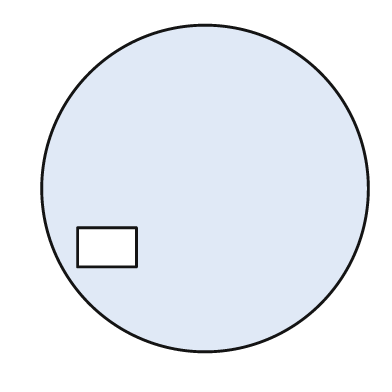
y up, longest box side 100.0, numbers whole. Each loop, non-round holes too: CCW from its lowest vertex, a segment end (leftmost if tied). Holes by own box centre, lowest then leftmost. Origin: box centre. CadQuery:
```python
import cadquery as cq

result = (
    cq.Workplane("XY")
    .moveTo(0.0, 0.0)
    .circle(50.0)
    .moveTo(-39.0, -24.0)
    .lineTo(-21.0, -24.0)
    .lineTo(-21.0, -12.0)
    .lineTo(-39.0, -12.0)
    .close()
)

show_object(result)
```